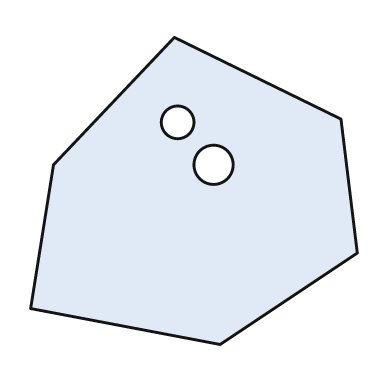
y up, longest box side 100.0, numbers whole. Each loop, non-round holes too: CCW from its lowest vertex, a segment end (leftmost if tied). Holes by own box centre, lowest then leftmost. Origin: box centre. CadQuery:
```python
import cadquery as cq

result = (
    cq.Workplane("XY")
    .moveTo(8.0, -47.0)
    .lineTo(50.0, -19.0)
    .lineTo(45.0, 22.0)
    .lineTo(-6.0, 47.0)
    .lineTo(-43.0, 8.0)
    .lineTo(-50.0, -36.0)
    .close()
    .moveTo(6.0, 8.0)
    .circle(6.0)
    .moveTo(-5.0, 21.0)
    .circle(5.0)
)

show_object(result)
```